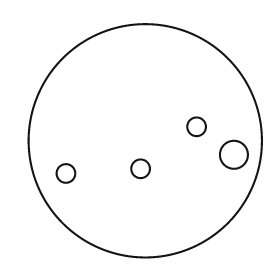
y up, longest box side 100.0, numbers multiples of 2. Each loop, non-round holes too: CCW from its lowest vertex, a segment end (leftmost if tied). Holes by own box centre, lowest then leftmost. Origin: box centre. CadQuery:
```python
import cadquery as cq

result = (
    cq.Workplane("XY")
    .moveTo(0.0, 0.0)
    .circle(50.0)
    .moveTo(-34.0, -14.0)
    .circle(4.0)
    .moveTo(-2.0, -12.0)
    .circle(4.0)
    .moveTo(38.0, -6.0)
    .circle(6.0)
    .moveTo(22.0, 6.0)
    .circle(4.0)
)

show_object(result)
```